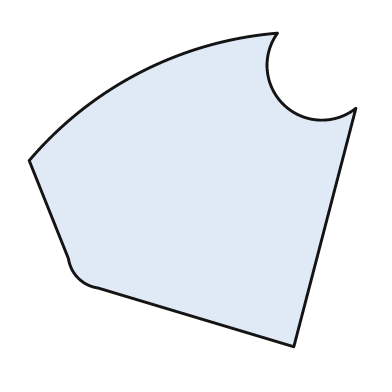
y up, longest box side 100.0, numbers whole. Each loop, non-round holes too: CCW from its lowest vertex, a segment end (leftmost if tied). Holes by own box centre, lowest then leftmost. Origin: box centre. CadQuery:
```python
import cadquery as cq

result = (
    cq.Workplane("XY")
    .moveTo(31.0, -48.0)
    .lineTo(50.0, 25.0)
    .threePointArc((28.0, 26.0), (26.0, 48.0))
    .threePointArc((-16.0, 36.0), (-50.0, 9.0))
    .lineTo(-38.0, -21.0)
    .threePointArc((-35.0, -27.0), (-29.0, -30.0))
    .close()
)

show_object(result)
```